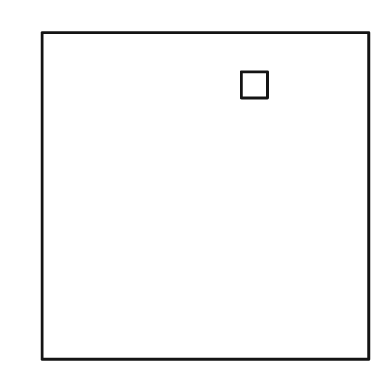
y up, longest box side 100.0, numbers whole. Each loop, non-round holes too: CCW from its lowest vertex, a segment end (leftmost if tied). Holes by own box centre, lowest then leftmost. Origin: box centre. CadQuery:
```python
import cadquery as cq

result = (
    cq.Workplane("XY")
    .moveTo(-50.0, -50.0)
    .lineTo(50.0, -50.0)
    .lineTo(50.0, 50.0)
    .lineTo(-50.0, 50.0)
    .close()
    .moveTo(11.0, 30.0)
    .lineTo(19.0, 30.0)
    .lineTo(19.0, 38.0)
    .lineTo(11.0, 38.0)
    .close()
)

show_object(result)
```